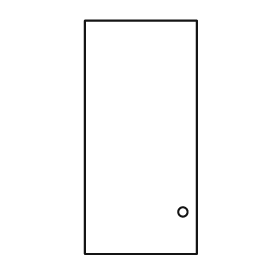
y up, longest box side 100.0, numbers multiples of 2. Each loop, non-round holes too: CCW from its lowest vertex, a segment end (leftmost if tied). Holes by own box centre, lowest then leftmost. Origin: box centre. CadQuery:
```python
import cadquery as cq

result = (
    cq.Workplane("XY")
    .moveTo(-24.0, -50.0)
    .lineTo(24.0, -50.0)
    .lineTo(24.0, 50.0)
    .lineTo(-24.0, 50.0)
    .close()
    .moveTo(18.0, -32.0)
    .circle(2.0)
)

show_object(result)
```